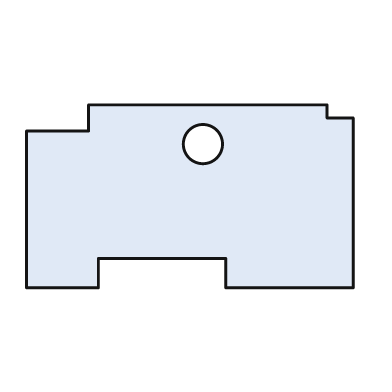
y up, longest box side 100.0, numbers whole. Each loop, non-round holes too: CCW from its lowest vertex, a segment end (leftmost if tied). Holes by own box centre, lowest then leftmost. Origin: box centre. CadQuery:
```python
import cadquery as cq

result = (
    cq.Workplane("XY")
    .moveTo(-50.0, -28.0)
    .lineTo(-28.0, -28.0)
    .lineTo(-28.0, -19.0)
    .lineTo(11.0, -19.0)
    .lineTo(11.0, -28.0)
    .lineTo(50.0, -28.0)
    .lineTo(50.0, 24.0)
    .lineTo(42.0, 24.0)
    .lineTo(42.0, 28.0)
    .lineTo(-31.0, 28.0)
    .lineTo(-31.0, 20.0)
    .lineTo(-50.0, 20.0)
    .close()
    .moveTo(4.0, 16.0)
    .circle(6.0)
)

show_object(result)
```